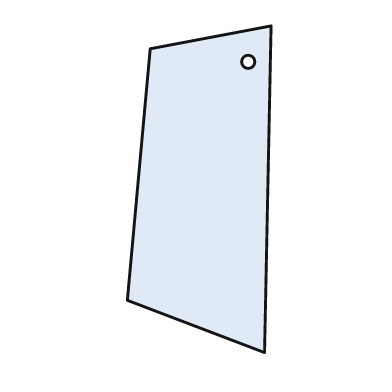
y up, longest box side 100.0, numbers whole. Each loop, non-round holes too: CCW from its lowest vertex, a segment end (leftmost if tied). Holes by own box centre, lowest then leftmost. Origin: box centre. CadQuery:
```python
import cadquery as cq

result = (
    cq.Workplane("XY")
    .moveTo(20.0, -50.0)
    .lineTo(22.0, 50.0)
    .lineTo(-15.0, 43.0)
    .lineTo(-22.0, -34.0)
    .close()
    .moveTo(15.0, 39.0)
    .circle(2.0)
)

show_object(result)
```